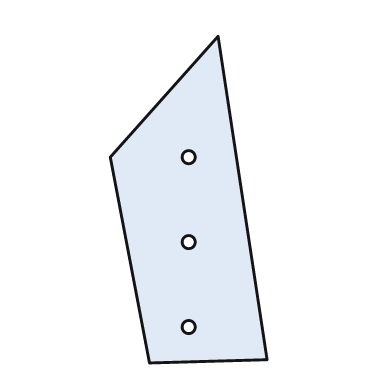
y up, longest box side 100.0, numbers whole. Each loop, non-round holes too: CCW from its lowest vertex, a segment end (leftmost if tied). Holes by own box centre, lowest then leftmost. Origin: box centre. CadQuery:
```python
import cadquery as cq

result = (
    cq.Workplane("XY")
    .moveTo(-12.0, -50.0)
    .lineTo(24.0, -49.0)
    .lineTo(9.0, 50.0)
    .lineTo(-24.0, 13.0)
    .close()
    .moveTo(0.0, -39.0)
    .circle(2.0)
    .moveTo(0.0, -13.0)
    .circle(2.0)
    .moveTo(0.0, 13.0)
    .circle(2.0)
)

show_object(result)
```